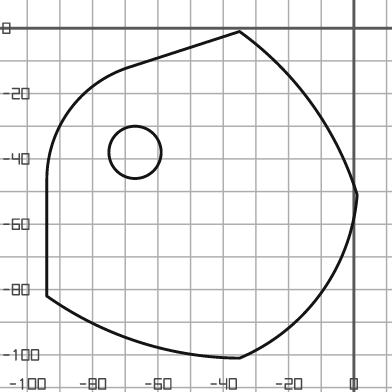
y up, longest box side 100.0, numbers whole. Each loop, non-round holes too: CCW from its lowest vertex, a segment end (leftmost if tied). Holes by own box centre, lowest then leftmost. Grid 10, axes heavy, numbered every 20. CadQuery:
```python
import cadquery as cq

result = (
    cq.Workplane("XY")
    .moveTo(-35.0, -101.0)
    .threePointArc((-10.0, -81.0), (1.0, -51.0))
    .threePointArc((-13.0, -23.0), (-35.0, -1.0))
    .lineTo(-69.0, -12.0)
    .threePointArc((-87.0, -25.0), (-94.0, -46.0))
    .lineTo(-94.0, -82.0)
    .threePointArc((-66.0, -96.0), (-35.0, -101.0))
    .close()
    .moveTo(-67.0, -38.0)
    .circle(8.0)
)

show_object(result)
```